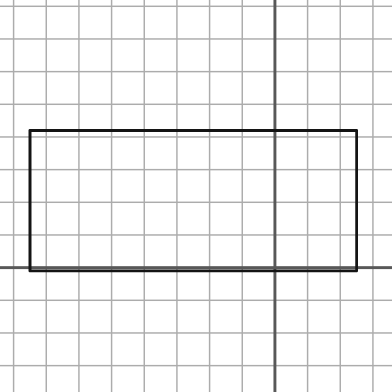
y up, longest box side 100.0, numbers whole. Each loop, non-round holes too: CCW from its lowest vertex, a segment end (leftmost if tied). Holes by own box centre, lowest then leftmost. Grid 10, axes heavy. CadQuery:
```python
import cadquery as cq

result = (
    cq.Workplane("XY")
    .moveTo(-75.0, -1.0)
    .lineTo(25.0, -1.0)
    .lineTo(25.0, 42.0)
    .lineTo(-75.0, 42.0)
    .close()
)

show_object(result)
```